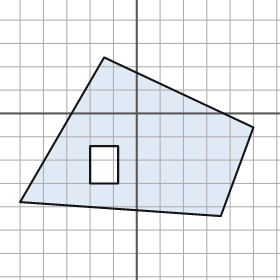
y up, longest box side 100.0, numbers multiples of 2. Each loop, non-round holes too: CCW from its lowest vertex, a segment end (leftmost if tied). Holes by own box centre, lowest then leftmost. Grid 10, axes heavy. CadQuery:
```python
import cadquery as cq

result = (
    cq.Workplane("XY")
    .moveTo(36.0, -44.0)
    .lineTo(50.0, -6.0)
    .lineTo(-14.0, 24.0)
    .lineTo(-50.0, -38.0)
    .close()
    .moveTo(-20.0, -30.0)
    .lineTo(-8.0, -30.0)
    .lineTo(-8.0, -14.0)
    .lineTo(-20.0, -14.0)
    .close()
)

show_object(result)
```